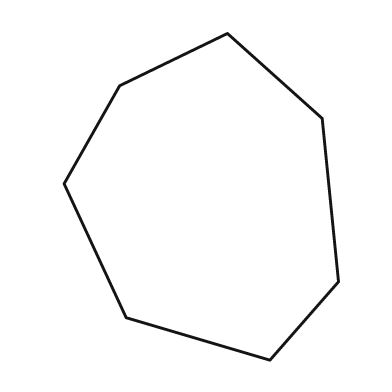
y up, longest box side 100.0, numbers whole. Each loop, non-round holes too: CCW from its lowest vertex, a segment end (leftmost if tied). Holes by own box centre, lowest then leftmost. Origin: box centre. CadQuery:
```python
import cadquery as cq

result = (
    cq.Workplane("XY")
    .moveTo(21.0, -50.0)
    .lineTo(42.0, -26.0)
    .lineTo(37.0, 24.0)
    .lineTo(8.0, 50.0)
    .lineTo(-25.0, 34.0)
    .lineTo(-42.0, 4.0)
    .lineTo(-23.0, -37.0)
    .close()
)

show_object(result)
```